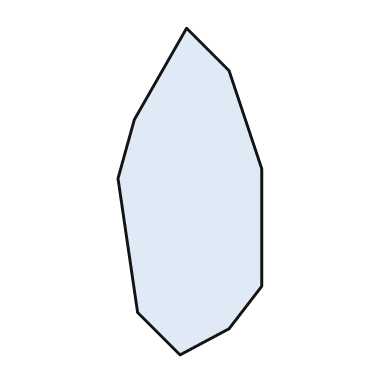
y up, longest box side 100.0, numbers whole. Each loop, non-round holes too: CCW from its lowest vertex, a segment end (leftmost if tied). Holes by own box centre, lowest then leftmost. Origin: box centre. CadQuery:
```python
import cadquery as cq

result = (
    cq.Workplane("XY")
    .moveTo(-3.0, -50.0)
    .lineTo(12.0, -42.0)
    .lineTo(22.0, -29.0)
    .lineTo(22.0, 7.0)
    .lineTo(12.0, 37.0)
    .lineTo(-1.0, 50.0)
    .lineTo(-17.0, 22.0)
    .lineTo(-22.0, 4.0)
    .lineTo(-16.0, -37.0)
    .close()
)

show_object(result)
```